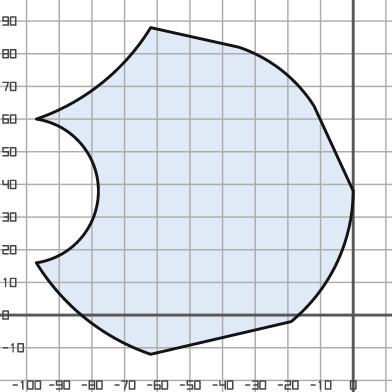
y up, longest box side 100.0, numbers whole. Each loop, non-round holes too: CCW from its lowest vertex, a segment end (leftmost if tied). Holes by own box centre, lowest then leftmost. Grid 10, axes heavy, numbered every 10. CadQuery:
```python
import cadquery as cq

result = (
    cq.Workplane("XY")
    .moveTo(-62.0, -12.0)
    .lineTo(-19.0, -2.0)
    .threePointArc((-5.0, 16.0), (0.0, 38.0))
    .lineTo(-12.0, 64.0)
    .threePointArc((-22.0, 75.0), (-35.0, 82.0))
    .lineTo(-62.0, 88.0)
    .threePointArc((-77.0, 71.0), (-97.0, 60.0))
    .threePointArc((-78.0, 38.0), (-97.0, 16.0))
    .threePointArc((-82.0, -1.0), (-62.0, -12.0))
    .close()
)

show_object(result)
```